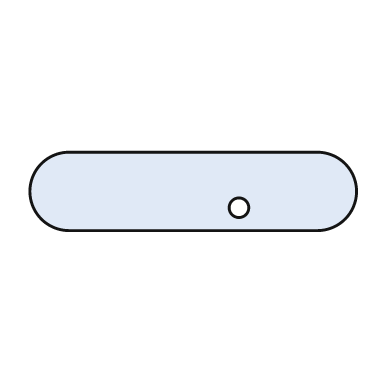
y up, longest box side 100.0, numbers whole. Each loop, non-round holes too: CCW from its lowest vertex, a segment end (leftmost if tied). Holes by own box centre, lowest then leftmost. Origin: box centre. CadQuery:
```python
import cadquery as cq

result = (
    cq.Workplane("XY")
    .moveTo(-38.0, -12.0)
    .lineTo(38.0, -12.0)
    .threePointArc((50.0, 0.0), (38.0, 12.0))
    .lineTo(-38.0, 12.0)
    .threePointArc((-50.0, 0.0), (-38.0, -12.0))
    .close()
    .moveTo(14.0, -5.0)
    .circle(3.0)
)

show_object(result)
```